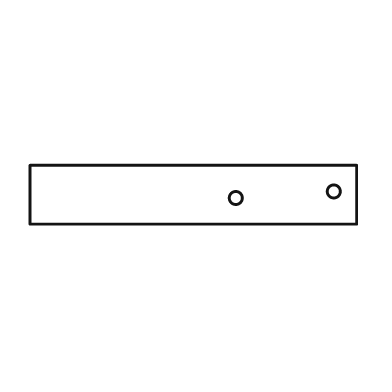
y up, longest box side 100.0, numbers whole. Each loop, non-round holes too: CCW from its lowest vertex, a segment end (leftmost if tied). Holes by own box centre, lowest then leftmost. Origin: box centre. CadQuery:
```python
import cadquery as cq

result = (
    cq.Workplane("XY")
    .moveTo(-50.0, -9.0)
    .lineTo(50.0, -9.0)
    .lineTo(50.0, 9.0)
    .lineTo(-50.0, 9.0)
    .close()
    .moveTo(13.0, -1.0)
    .circle(2.0)
    .moveTo(43.0, 1.0)
    .circle(2.0)
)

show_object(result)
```